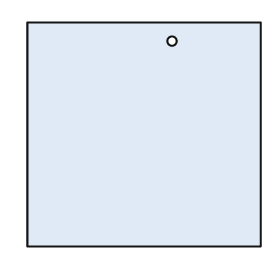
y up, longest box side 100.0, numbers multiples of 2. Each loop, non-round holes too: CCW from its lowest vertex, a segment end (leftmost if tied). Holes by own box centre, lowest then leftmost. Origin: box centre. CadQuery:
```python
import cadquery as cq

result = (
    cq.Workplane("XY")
    .moveTo(-50.0, -48.0)
    .lineTo(50.0, -48.0)
    .lineTo(50.0, 48.0)
    .lineTo(-50.0, 48.0)
    .close()
    .moveTo(12.0, 40.0)
    .circle(2.0)
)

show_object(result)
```